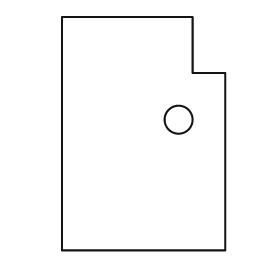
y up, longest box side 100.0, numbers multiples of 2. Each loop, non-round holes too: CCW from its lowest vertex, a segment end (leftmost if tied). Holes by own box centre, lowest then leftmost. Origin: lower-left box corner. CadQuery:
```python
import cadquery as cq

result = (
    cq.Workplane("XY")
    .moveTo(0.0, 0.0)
    .lineTo(70.0, 0.0)
    .lineTo(70.0, 76.0)
    .lineTo(56.0, 76.0)
    .lineTo(56.0, 100.0)
    .lineTo(0.0, 100.0)
    .close()
    .moveTo(50.0, 56.0)
    .circle(6.0)
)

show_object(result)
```